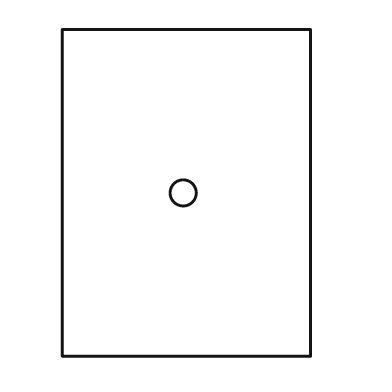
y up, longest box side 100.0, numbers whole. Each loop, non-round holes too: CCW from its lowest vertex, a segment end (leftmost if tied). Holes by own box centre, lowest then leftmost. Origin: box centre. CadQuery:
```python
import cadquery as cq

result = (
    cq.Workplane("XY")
    .moveTo(-38.0, -50.0)
    .lineTo(38.0, -50.0)
    .lineTo(38.0, 50.0)
    .lineTo(-38.0, 50.0)
    .close()
    .moveTo(-1.0, 0.0)
    .circle(4.0)
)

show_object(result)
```